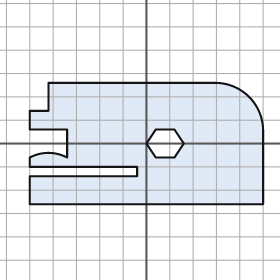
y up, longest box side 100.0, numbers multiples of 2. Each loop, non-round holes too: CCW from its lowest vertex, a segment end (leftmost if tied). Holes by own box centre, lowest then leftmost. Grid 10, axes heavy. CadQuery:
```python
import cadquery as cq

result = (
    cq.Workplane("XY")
    .moveTo(-50.0, -26.0)
    .lineTo(50.0, -26.0)
    .lineTo(50.0, 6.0)
    .threePointArc((44.0, 20.0), (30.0, 26.0))
    .lineTo(-42.0, 26.0)
    .lineTo(-42.0, 14.0)
    .lineTo(-50.0, 14.0)
    .lineTo(-50.0, 6.0)
    .lineTo(-34.0, 6.0)
    .lineTo(-34.0, -6.0)
    .threePointArc((-42.0, -4.0), (-50.0, -6.0))
    .lineTo(-50.0, -10.0)
    .lineTo(-4.0, -10.0)
    .lineTo(-4.0, -14.0)
    .lineTo(-50.0, -14.0)
    .close()
    .moveTo(4.0, -6.0)
    .lineTo(12.0, -6.0)
    .lineTo(16.0, 0.0)
    .lineTo(12.0, 6.0)
    .lineTo(4.0, 6.0)
    .lineTo(0.0, 0.0)
    .close()
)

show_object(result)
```